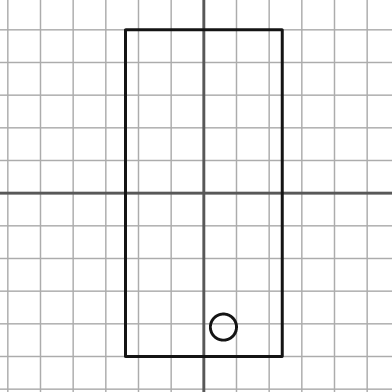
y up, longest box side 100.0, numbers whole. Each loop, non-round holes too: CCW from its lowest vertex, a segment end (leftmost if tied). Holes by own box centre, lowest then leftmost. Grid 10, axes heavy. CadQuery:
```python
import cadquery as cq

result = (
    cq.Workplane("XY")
    .moveTo(-24.0, -50.0)
    .lineTo(24.0, -50.0)
    .lineTo(24.0, 50.0)
    .lineTo(-24.0, 50.0)
    .close()
    .moveTo(6.0, -41.0)
    .circle(4.0)
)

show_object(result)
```